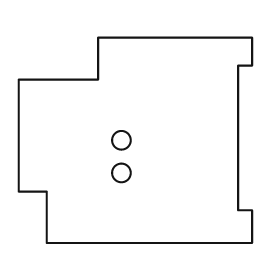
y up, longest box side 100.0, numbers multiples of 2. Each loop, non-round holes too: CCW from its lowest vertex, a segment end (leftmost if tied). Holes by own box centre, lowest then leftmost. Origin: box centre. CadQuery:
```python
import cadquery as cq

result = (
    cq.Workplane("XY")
    .moveTo(-38.0, -44.0)
    .lineTo(50.0, -44.0)
    .lineTo(50.0, -30.0)
    .lineTo(44.0, -30.0)
    .lineTo(44.0, 32.0)
    .lineTo(50.0, 32.0)
    .lineTo(50.0, 44.0)
    .lineTo(-16.0, 44.0)
    .lineTo(-16.0, 26.0)
    .lineTo(-50.0, 26.0)
    .lineTo(-50.0, -22.0)
    .lineTo(-38.0, -22.0)
    .close()
    .moveTo(-6.0, -14.0)
    .circle(4.0)
    .moveTo(-6.0, 0.0)
    .circle(4.0)
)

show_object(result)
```